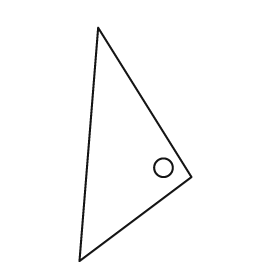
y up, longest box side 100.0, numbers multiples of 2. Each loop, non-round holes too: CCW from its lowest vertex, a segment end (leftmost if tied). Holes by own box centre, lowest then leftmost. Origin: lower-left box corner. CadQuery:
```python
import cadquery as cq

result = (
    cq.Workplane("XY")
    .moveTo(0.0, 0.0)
    .lineTo(48.0, 36.0)
    .lineTo(8.0, 100.0)
    .close()
    .moveTo(36.0, 40.0)
    .circle(4.0)
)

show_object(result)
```